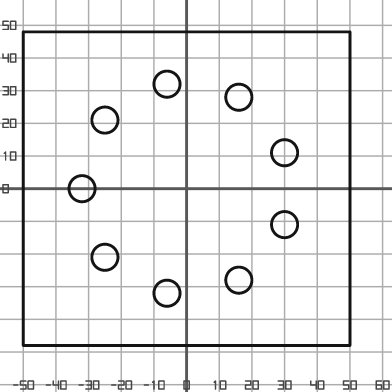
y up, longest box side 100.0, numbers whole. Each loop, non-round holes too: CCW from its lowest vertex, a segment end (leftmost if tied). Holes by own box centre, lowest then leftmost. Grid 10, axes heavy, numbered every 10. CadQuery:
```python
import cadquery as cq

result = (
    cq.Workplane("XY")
    .moveTo(-50.0, -48.0)
    .lineTo(50.0, -48.0)
    .lineTo(50.0, 48.0)
    .lineTo(-50.0, 48.0)
    .close()
    .moveTo(-6.0, -32.0)
    .circle(4.0)
    .moveTo(16.0, -28.0)
    .circle(4.0)
    .moveTo(-25.0, -21.0)
    .circle(4.0)
    .moveTo(30.0, -11.0)
    .circle(4.0)
    .moveTo(-32.0, 0.0)
    .circle(4.0)
    .moveTo(30.0, 11.0)
    .circle(4.0)
    .moveTo(-25.0, 21.0)
    .circle(4.0)
    .moveTo(16.0, 28.0)
    .circle(4.0)
    .moveTo(-6.0, 32.0)
    .circle(4.0)
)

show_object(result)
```